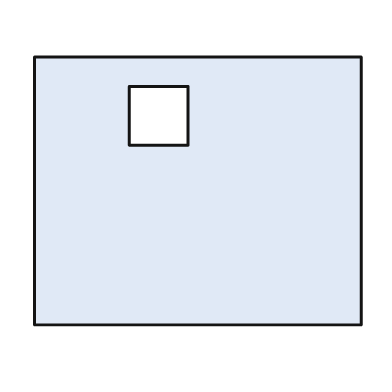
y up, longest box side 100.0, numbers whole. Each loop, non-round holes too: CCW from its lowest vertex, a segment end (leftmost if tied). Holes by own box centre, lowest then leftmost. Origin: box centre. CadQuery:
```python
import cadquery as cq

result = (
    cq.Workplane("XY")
    .moveTo(-50.0, -41.0)
    .lineTo(50.0, -41.0)
    .lineTo(50.0, 41.0)
    .lineTo(-50.0, 41.0)
    .close()
    .moveTo(-21.0, 14.0)
    .lineTo(-3.0, 14.0)
    .lineTo(-3.0, 32.0)
    .lineTo(-21.0, 32.0)
    .close()
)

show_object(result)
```